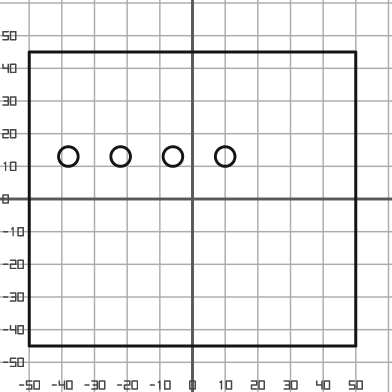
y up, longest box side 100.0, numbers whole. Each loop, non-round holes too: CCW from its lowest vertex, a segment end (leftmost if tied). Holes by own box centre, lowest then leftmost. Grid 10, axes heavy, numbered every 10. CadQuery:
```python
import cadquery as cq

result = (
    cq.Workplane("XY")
    .moveTo(-50.0, -45.0)
    .lineTo(50.0, -45.0)
    .lineTo(50.0, 45.0)
    .lineTo(-50.0, 45.0)
    .close()
    .moveTo(-38.0, 13.0)
    .circle(3.0)
    .moveTo(-22.0, 13.0)
    .circle(3.0)
    .moveTo(-6.0, 13.0)
    .circle(3.0)
    .moveTo(10.0, 13.0)
    .circle(3.0)
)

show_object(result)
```